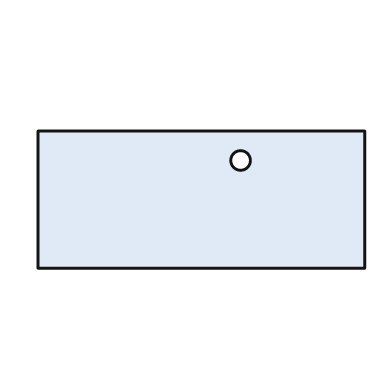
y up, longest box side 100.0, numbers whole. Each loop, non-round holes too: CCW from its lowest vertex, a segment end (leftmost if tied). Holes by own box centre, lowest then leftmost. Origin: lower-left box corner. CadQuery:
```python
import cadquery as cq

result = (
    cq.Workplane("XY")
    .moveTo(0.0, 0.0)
    .lineTo(100.0, 0.0)
    .lineTo(100.0, 42.0)
    .lineTo(0.0, 42.0)
    .close()
    .moveTo(62.0, 33.0)
    .circle(3.0)
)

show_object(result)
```